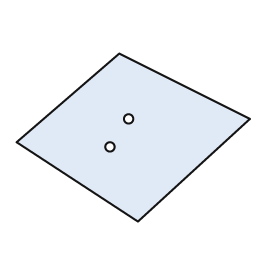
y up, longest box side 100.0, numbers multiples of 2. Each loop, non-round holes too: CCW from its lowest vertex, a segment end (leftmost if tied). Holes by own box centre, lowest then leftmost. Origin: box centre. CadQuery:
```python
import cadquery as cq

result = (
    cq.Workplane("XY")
    .moveTo(2.0, -36.0)
    .lineTo(50.0, 8.0)
    .lineTo(-6.0, 36.0)
    .lineTo(-50.0, -2.0)
    .close()
    .moveTo(-10.0, -4.0)
    .circle(2.0)
    .moveTo(-2.0, 8.0)
    .circle(2.0)
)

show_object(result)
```